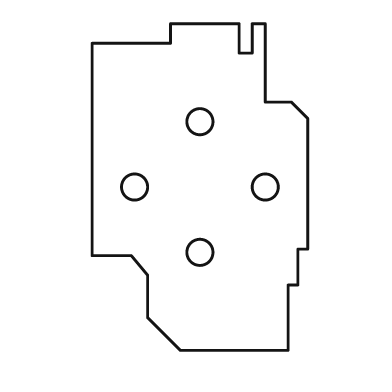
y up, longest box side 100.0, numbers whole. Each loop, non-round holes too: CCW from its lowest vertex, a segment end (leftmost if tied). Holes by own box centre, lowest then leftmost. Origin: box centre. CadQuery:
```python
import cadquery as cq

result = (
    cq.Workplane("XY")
    .moveTo(-6.0, -50.0)
    .lineTo(27.0, -50.0)
    .lineTo(27.0, -30.0)
    .lineTo(30.0, -30.0)
    .lineTo(30.0, -19.0)
    .lineTo(33.0, -19.0)
    .lineTo(33.0, 21.0)
    .lineTo(28.0, 26.0)
    .lineTo(20.0, 26.0)
    .lineTo(20.0, 50.0)
    .lineTo(16.0, 50.0)
    .lineTo(16.0, 41.0)
    .lineTo(12.0, 41.0)
    .lineTo(12.0, 50.0)
    .lineTo(-9.0, 50.0)
    .lineTo(-9.0, 44.0)
    .lineTo(-33.0, 44.0)
    .lineTo(-33.0, -21.0)
    .lineTo(-21.0, -21.0)
    .lineTo(-16.0, -27.0)
    .lineTo(-16.0, -40.0)
    .close()
    .moveTo(0.0, -20.0)
    .circle(4.0)
    .moveTo(-20.0, 0.0)
    .circle(4.0)
    .moveTo(20.0, 0.0)
    .circle(4.0)
    .moveTo(0.0, 20.0)
    .circle(4.0)
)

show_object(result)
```